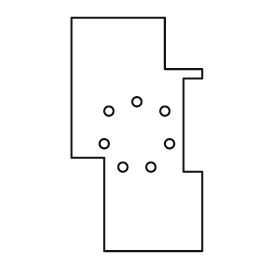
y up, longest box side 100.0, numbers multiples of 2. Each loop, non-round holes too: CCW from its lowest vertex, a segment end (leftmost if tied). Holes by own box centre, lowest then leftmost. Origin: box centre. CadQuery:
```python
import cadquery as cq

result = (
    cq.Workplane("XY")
    .moveTo(-14.0, -50.0)
    .lineTo(28.0, -50.0)
    .lineTo(28.0, -16.0)
    .lineTo(20.0, -16.0)
    .lineTo(20.0, 24.0)
    .lineTo(28.0, 24.0)
    .lineTo(28.0, 28.0)
    .lineTo(12.0, 28.0)
    .lineTo(12.0, 50.0)
    .lineTo(-28.0, 50.0)
    .lineTo(-28.0, -10.0)
    .lineTo(-14.0, -10.0)
    .close()
    .moveTo(-6.0, -14.0)
    .circle(2.0)
    .moveTo(6.0, -14.0)
    .circle(2.0)
    .moveTo(-14.0, -4.0)
    .circle(2.0)
    .moveTo(14.0, -4.0)
    .circle(2.0)
    .moveTo(-12.0, 10.0)
    .circle(2.0)
    .moveTo(12.0, 10.0)
    .circle(2.0)
    .moveTo(0.0, 14.0)
    .circle(2.0)
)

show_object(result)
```